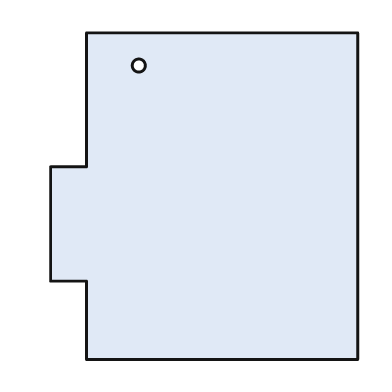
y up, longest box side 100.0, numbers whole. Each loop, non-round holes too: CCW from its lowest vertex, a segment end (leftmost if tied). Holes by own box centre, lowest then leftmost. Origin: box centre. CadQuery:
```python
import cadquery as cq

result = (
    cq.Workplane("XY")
    .moveTo(-36.0, -50.0)
    .lineTo(47.0, -50.0)
    .lineTo(47.0, 50.0)
    .lineTo(-36.0, 50.0)
    .lineTo(-36.0, 9.0)
    .lineTo(-47.0, 9.0)
    .lineTo(-47.0, -26.0)
    .lineTo(-36.0, -26.0)
    .close()
    .moveTo(-20.0, 40.0)
    .circle(2.0)
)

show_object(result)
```